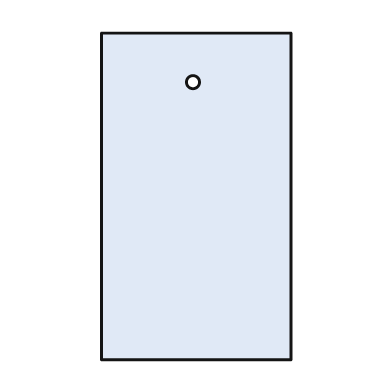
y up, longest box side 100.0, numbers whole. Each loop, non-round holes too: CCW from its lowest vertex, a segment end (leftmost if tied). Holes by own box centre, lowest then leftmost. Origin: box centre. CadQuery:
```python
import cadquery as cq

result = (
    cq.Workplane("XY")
    .moveTo(-29.0, -50.0)
    .lineTo(29.0, -50.0)
    .lineTo(29.0, 50.0)
    .lineTo(-29.0, 50.0)
    .close()
    .moveTo(-1.0, 35.0)
    .circle(2.0)
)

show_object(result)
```